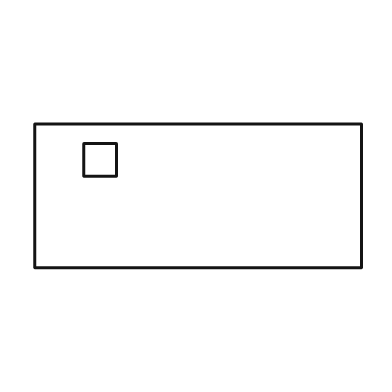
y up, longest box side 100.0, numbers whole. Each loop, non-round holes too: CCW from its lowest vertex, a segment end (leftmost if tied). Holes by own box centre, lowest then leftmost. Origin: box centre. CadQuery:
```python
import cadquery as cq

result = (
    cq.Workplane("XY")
    .moveTo(-50.0, -22.0)
    .lineTo(50.0, -22.0)
    .lineTo(50.0, 22.0)
    .lineTo(-50.0, 22.0)
    .close()
    .moveTo(-35.0, 6.0)
    .lineTo(-25.0, 6.0)
    .lineTo(-25.0, 16.0)
    .lineTo(-35.0, 16.0)
    .close()
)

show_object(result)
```